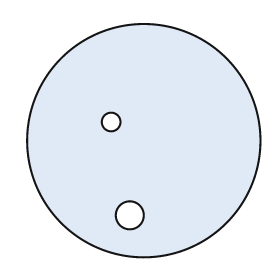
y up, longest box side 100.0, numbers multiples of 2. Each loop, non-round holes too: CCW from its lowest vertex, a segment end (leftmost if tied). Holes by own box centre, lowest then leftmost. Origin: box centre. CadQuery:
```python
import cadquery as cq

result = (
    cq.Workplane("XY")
    .moveTo(0.0, 0.0)
    .circle(50.0)
    .moveTo(-6.0, -32.0)
    .circle(6.0)
    .moveTo(-14.0, 8.0)
    .circle(4.0)
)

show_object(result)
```